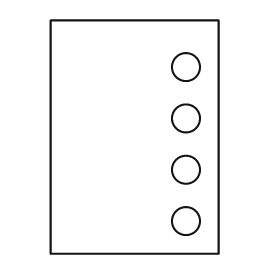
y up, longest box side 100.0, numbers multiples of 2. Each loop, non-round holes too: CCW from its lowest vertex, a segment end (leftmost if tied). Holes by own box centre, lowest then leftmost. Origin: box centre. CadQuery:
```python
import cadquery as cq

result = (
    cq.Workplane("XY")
    .moveTo(-36.0, -50.0)
    .lineTo(36.0, -50.0)
    .lineTo(36.0, 50.0)
    .lineTo(-36.0, 50.0)
    .close()
    .moveTo(22.0, -36.0)
    .circle(6.0)
    .moveTo(22.0, -14.0)
    .circle(6.0)
    .moveTo(22.0, 8.0)
    .circle(6.0)
    .moveTo(22.0, 30.0)
    .circle(6.0)
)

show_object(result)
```